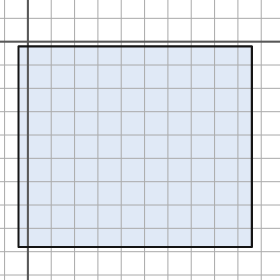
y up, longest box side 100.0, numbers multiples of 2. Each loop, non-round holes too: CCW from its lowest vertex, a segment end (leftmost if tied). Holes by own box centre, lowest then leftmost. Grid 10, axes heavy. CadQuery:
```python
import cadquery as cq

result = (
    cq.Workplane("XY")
    .moveTo(-4.0, -88.0)
    .lineTo(96.0, -88.0)
    .lineTo(96.0, -2.0)
    .lineTo(-4.0, -2.0)
    .close()
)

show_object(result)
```